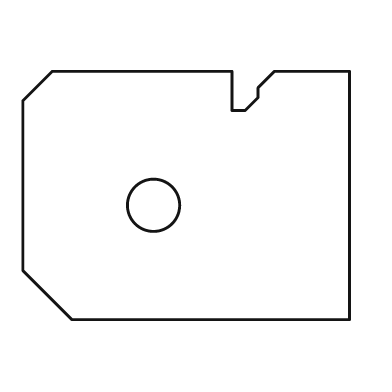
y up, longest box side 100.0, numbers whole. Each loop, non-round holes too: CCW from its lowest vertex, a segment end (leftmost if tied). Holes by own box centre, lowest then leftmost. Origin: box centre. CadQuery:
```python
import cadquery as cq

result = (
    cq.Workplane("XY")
    .moveTo(-35.0, -38.0)
    .lineTo(50.0, -38.0)
    .lineTo(50.0, 38.0)
    .lineTo(27.0, 38.0)
    .lineTo(22.0, 33.0)
    .lineTo(22.0, 30.0)
    .lineTo(18.0, 26.0)
    .lineTo(14.0, 26.0)
    .lineTo(14.0, 38.0)
    .lineTo(-41.0, 38.0)
    .lineTo(-50.0, 29.0)
    .lineTo(-50.0, -23.0)
    .close()
    .moveTo(-10.0, -3.0)
    .circle(8.0)
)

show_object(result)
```